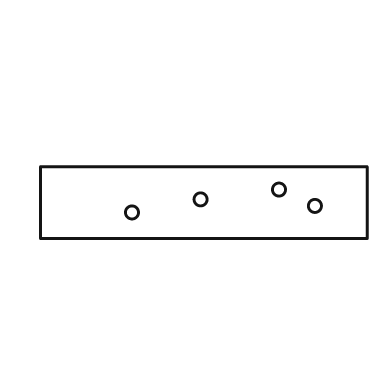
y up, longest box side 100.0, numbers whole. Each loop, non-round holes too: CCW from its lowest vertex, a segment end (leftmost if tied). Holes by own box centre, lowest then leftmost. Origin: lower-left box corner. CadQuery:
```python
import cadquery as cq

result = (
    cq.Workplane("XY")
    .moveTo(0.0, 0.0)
    .lineTo(100.0, 0.0)
    .lineTo(100.0, 22.0)
    .lineTo(0.0, 22.0)
    .close()
    .moveTo(28.0, 8.0)
    .circle(2.0)
    .moveTo(84.0, 10.0)
    .circle(2.0)
    .moveTo(49.0, 12.0)
    .circle(2.0)
    .moveTo(73.0, 15.0)
    .circle(2.0)
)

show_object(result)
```